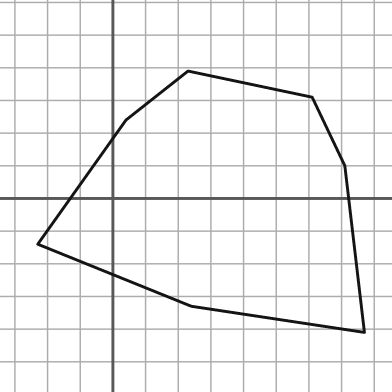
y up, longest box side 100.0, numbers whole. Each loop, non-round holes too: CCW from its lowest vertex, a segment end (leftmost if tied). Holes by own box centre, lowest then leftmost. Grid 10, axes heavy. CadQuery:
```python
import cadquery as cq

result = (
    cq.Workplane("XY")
    .moveTo(77.0, -41.0)
    .lineTo(71.0, 10.0)
    .lineTo(61.0, 31.0)
    .lineTo(23.0, 39.0)
    .lineTo(4.0, 24.0)
    .lineTo(-23.0, -14.0)
    .lineTo(24.0, -33.0)
    .close()
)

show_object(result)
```